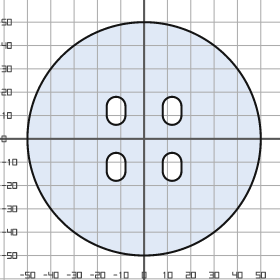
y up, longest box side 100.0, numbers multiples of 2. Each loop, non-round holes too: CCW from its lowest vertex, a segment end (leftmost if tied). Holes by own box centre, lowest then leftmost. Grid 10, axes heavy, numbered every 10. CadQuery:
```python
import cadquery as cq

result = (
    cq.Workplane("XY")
    .moveTo(0.0, 0.0)
    .circle(50.0)
    .moveTo(-16.0, -14.0)
    .threePointArc((-12.0, -18.0), (-8.0, -14.0))
    .lineTo(-8.0, -10.0)
    .threePointArc((-12.0, -6.0), (-16.0, -10.0))
    .close()
    .moveTo(8.0, -14.0)
    .threePointArc((12.0, -18.0), (16.0, -14.0))
    .lineTo(16.0, -10.0)
    .threePointArc((12.0, -6.0), (8.0, -10.0))
    .close()
    .moveTo(-16.0, 10.0)
    .threePointArc((-12.0, 6.0), (-8.0, 10.0))
    .lineTo(-8.0, 14.0)
    .threePointArc((-12.0, 18.0), (-16.0, 14.0))
    .close()
    .moveTo(8.0, 10.0)
    .threePointArc((12.0, 6.0), (16.0, 10.0))
    .lineTo(16.0, 14.0)
    .threePointArc((12.0, 18.0), (8.0, 14.0))
    .close()
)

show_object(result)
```